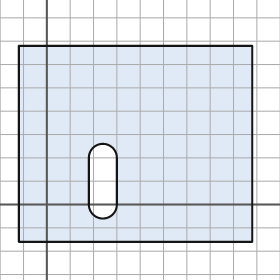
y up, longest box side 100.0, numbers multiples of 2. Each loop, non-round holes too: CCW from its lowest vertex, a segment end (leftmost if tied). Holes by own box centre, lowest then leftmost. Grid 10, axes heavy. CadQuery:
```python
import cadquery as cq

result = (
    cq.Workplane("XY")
    .moveTo(-12.0, -16.0)
    .lineTo(88.0, -16.0)
    .lineTo(88.0, 68.0)
    .lineTo(-12.0, 68.0)
    .close()
    .moveTo(18.0, 0.0)
    .threePointArc((24.0, -6.0), (30.0, 0.0))
    .lineTo(30.0, 20.0)
    .threePointArc((24.0, 26.0), (18.0, 20.0))
    .close()
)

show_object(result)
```